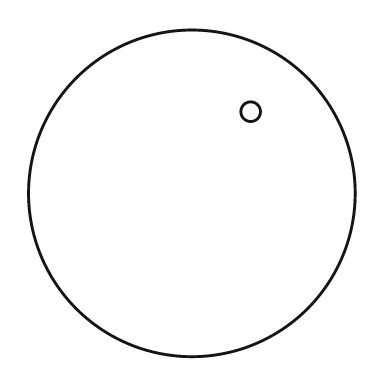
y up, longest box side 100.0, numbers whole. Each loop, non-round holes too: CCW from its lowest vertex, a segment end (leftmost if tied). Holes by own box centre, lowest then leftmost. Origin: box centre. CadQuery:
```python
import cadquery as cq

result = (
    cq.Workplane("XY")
    .moveTo(0.0, 0.0)
    .circle(50.0)
    .moveTo(18.0, 25.0)
    .circle(3.0)
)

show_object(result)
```